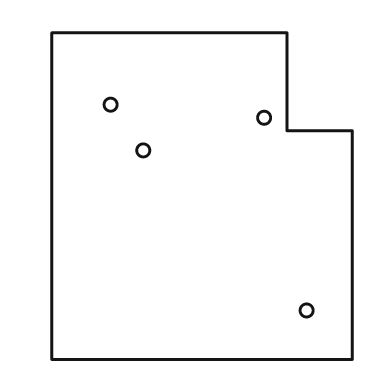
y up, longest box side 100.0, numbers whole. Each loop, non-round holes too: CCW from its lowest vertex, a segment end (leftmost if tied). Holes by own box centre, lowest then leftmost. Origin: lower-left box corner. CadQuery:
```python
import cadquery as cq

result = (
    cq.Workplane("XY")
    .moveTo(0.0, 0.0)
    .lineTo(92.0, 0.0)
    .lineTo(92.0, 70.0)
    .lineTo(72.0, 70.0)
    .lineTo(72.0, 100.0)
    .lineTo(0.0, 100.0)
    .close()
    .moveTo(78.0, 15.0)
    .circle(2.0)
    .moveTo(28.0, 64.0)
    .circle(2.0)
    .moveTo(65.0, 74.0)
    .circle(2.0)
    .moveTo(18.0, 78.0)
    .circle(2.0)
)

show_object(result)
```